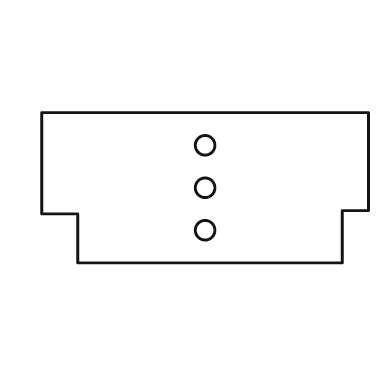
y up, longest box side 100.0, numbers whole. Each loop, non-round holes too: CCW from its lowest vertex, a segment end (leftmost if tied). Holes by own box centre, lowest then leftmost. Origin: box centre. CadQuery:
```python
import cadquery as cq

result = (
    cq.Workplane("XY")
    .moveTo(-39.0, -23.0)
    .lineTo(42.0, -23.0)
    .lineTo(42.0, -7.0)
    .lineTo(50.0, -7.0)
    .lineTo(50.0, 23.0)
    .lineTo(-50.0, 23.0)
    .lineTo(-50.0, -8.0)
    .lineTo(-39.0, -8.0)
    .close()
    .moveTo(0.0, -13.0)
    .circle(3.0)
    .moveTo(0.0, 0.0)
    .circle(3.0)
    .moveTo(0.0, 13.0)
    .circle(3.0)
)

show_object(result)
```